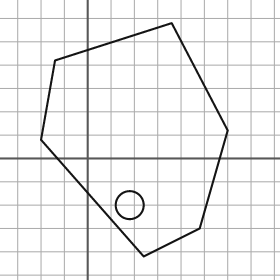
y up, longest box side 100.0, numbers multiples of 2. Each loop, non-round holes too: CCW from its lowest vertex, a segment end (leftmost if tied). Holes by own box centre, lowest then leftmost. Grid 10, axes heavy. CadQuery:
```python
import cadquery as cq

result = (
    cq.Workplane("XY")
    .moveTo(24.0, -42.0)
    .lineTo(48.0, -30.0)
    .lineTo(60.0, 12.0)
    .lineTo(36.0, 58.0)
    .lineTo(-14.0, 42.0)
    .lineTo(-20.0, 8.0)
    .close()
    .moveTo(18.0, -20.0)
    .circle(6.0)
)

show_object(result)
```